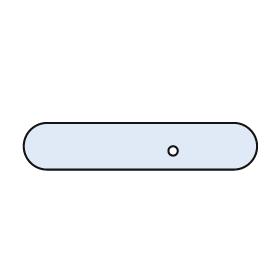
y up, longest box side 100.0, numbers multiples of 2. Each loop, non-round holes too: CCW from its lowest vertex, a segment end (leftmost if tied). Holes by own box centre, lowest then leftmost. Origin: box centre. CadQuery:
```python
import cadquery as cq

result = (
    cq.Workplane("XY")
    .moveTo(-40.0, -10.0)
    .lineTo(40.0, -10.0)
    .threePointArc((50.0, 0.0), (40.0, 10.0))
    .lineTo(-40.0, 10.0)
    .threePointArc((-50.0, 0.0), (-40.0, -10.0))
    .close()
    .moveTo(14.0, -2.0)
    .circle(2.0)
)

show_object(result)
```